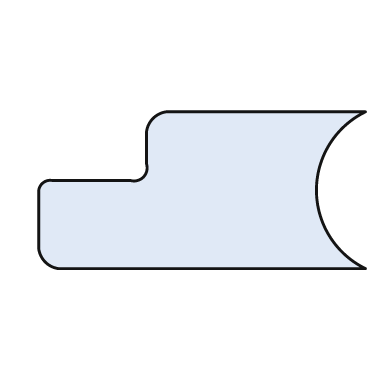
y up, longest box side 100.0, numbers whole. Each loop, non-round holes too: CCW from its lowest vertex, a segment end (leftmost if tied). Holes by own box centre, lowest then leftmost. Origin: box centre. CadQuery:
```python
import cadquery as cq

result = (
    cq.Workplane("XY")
    .moveTo(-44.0, -24.0)
    .lineTo(50.0, -24.0)
    .threePointArc((35.0, 0.0), (50.0, 24.0))
    .lineTo(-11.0, 24.0)
    .threePointArc((-15.0, 22.0), (-17.0, 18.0))
    .lineTo(-17.0, 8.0)
    .threePointArc((-18.0, 4.0), (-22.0, 3.0))
    .lineTo(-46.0, 3.0)
    .threePointArc((-49.0, 2.0), (-50.0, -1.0))
    .lineTo(-50.0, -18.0)
    .threePointArc((-48.0, -22.0), (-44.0, -24.0))
    .close()
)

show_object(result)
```